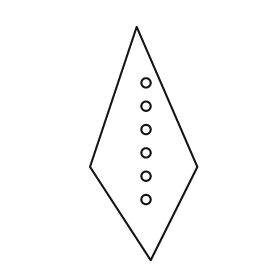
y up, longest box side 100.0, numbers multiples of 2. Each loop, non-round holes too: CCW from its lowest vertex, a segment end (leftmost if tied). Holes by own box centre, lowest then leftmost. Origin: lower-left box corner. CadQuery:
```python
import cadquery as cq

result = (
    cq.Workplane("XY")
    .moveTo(26.0, 0.0)
    .lineTo(46.0, 40.0)
    .lineTo(20.0, 100.0)
    .lineTo(0.0, 40.0)
    .close()
    .moveTo(24.0, 26.0)
    .circle(2.0)
    .moveTo(24.0, 36.0)
    .circle(2.0)
    .moveTo(24.0, 46.0)
    .circle(2.0)
    .moveTo(24.0, 56.0)
    .circle(2.0)
    .moveTo(24.0, 66.0)
    .circle(2.0)
    .moveTo(24.0, 76.0)
    .circle(2.0)
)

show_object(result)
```